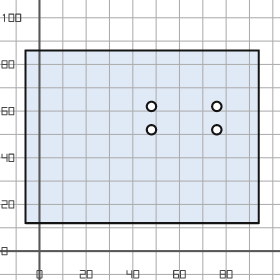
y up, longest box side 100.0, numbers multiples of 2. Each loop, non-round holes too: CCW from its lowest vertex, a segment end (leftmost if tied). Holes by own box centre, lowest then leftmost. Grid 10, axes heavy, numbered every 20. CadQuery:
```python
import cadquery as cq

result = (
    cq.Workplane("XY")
    .moveTo(-6.0, 12.0)
    .lineTo(94.0, 12.0)
    .lineTo(94.0, 86.0)
    .lineTo(-6.0, 86.0)
    .close()
    .moveTo(48.0, 52.0)
    .circle(2.0)
    .moveTo(76.0, 52.0)
    .circle(2.0)
    .moveTo(48.0, 62.0)
    .circle(2.0)
    .moveTo(76.0, 62.0)
    .circle(2.0)
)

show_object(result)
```